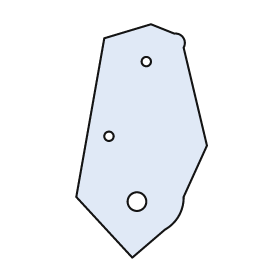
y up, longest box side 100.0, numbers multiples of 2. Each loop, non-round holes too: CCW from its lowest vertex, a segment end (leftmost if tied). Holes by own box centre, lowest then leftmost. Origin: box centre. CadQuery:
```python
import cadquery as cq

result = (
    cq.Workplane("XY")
    .moveTo(-4.0, -50.0)
    .lineTo(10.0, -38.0)
    .threePointArc((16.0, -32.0), (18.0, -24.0))
    .lineTo(28.0, -2.0)
    .lineTo(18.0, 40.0)
    .threePointArc((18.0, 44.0), (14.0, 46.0))
    .lineTo(4.0, 50.0)
    .lineTo(-16.0, 44.0)
    .lineTo(-28.0, -24.0)
    .close()
    .moveTo(-2.0, -26.0)
    .circle(4.0)
    .moveTo(-14.0, 2.0)
    .circle(2.0)
    .moveTo(2.0, 34.0)
    .circle(2.0)
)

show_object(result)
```